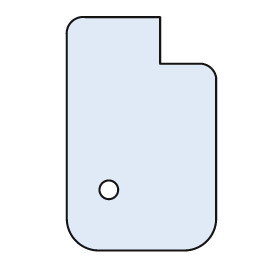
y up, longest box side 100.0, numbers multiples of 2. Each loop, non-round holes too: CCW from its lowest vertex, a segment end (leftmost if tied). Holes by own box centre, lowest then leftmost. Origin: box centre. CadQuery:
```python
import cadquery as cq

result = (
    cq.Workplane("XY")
    .moveTo(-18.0, -50.0)
    .lineTo(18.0, -50.0)
    .threePointArc((28.0, -46.0), (32.0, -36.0))
    .lineTo(32.0, 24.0)
    .threePointArc((30.0, 28.0), (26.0, 30.0))
    .lineTo(8.0, 30.0)
    .lineTo(8.0, 50.0)
    .lineTo(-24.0, 50.0)
    .threePointArc((-30.0, 48.0), (-32.0, 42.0))
    .lineTo(-32.0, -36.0)
    .threePointArc((-28.0, -46.0), (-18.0, -50.0))
    .close()
    .moveTo(-14.0, -24.0)
    .circle(4.0)
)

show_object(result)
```